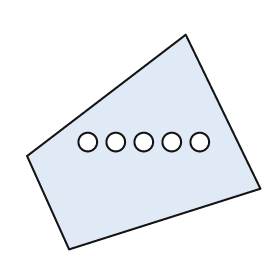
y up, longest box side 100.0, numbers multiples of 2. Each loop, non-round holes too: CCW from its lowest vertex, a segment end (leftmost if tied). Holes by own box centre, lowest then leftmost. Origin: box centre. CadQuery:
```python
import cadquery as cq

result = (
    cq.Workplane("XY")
    .moveTo(-32.0, -46.0)
    .lineTo(50.0, -20.0)
    .lineTo(18.0, 46.0)
    .lineTo(-50.0, -6.0)
    .close()
    .moveTo(-24.0, 0.0)
    .circle(4.0)
    .moveTo(-12.0, 0.0)
    .circle(4.0)
    .moveTo(0.0, 0.0)
    .circle(4.0)
    .moveTo(12.0, 0.0)
    .circle(4.0)
    .moveTo(24.0, 0.0)
    .circle(4.0)
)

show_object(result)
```